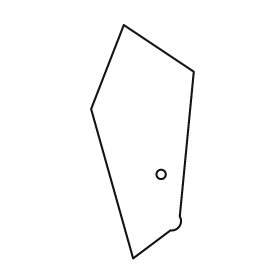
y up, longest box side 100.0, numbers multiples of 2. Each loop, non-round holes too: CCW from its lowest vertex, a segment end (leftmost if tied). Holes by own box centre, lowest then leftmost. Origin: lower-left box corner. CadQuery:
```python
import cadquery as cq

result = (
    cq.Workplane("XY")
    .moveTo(18.0, 0.0)
    .lineTo(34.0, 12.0)
    .threePointArc((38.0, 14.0), (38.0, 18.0))
    .lineTo(44.0, 80.0)
    .lineTo(14.0, 100.0)
    .lineTo(0.0, 64.0)
    .close()
    .moveTo(30.0, 36.0)
    .circle(2.0)
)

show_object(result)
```